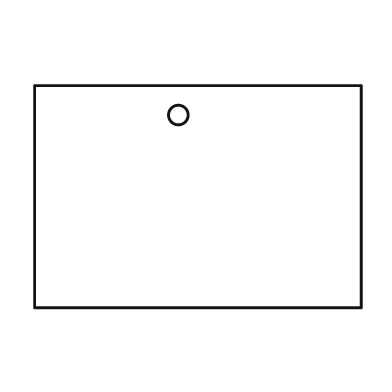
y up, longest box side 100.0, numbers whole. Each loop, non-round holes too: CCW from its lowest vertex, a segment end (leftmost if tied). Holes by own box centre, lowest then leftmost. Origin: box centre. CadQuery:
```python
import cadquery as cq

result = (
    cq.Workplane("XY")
    .moveTo(-50.0, -34.0)
    .lineTo(50.0, -34.0)
    .lineTo(50.0, 34.0)
    .lineTo(-50.0, 34.0)
    .close()
    .moveTo(-6.0, 25.0)
    .circle(3.0)
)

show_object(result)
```